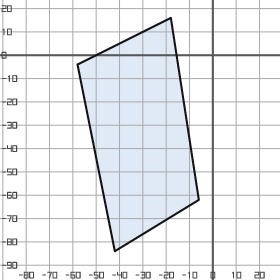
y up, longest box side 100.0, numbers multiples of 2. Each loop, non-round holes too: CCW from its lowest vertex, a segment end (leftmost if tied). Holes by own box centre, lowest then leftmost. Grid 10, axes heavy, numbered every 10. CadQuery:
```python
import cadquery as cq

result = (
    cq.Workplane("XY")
    .moveTo(-42.0, -84.0)
    .lineTo(-6.0, -62.0)
    .lineTo(-18.0, 16.0)
    .lineTo(-58.0, -4.0)
    .close()
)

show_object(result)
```